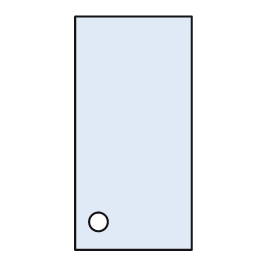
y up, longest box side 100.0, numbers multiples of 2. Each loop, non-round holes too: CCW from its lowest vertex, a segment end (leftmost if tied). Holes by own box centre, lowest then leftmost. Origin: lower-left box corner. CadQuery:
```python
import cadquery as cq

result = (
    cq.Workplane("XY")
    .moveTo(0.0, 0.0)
    .lineTo(50.0, 0.0)
    .lineTo(50.0, 100.0)
    .lineTo(0.0, 100.0)
    .close()
    .moveTo(10.0, 12.0)
    .circle(4.0)
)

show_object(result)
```